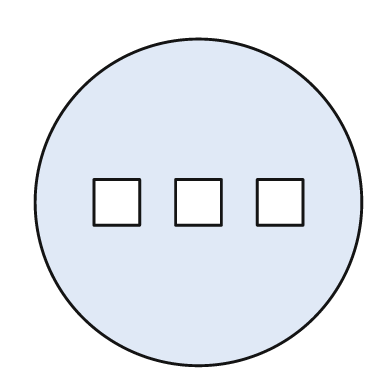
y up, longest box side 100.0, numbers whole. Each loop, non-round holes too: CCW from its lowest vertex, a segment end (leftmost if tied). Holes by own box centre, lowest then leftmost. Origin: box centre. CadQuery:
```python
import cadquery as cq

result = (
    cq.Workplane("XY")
    .moveTo(0.0, 0.0)
    .circle(50.0)
    .moveTo(-32.0, -7.0)
    .lineTo(-18.0, -7.0)
    .lineTo(-18.0, 7.0)
    .lineTo(-32.0, 7.0)
    .close()
    .moveTo(-7.0, -7.0)
    .lineTo(7.0, -7.0)
    .lineTo(7.0, 7.0)
    .lineTo(-7.0, 7.0)
    .close()
    .moveTo(18.0, -7.0)
    .lineTo(32.0, -7.0)
    .lineTo(32.0, 7.0)
    .lineTo(18.0, 7.0)
    .close()
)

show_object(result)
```